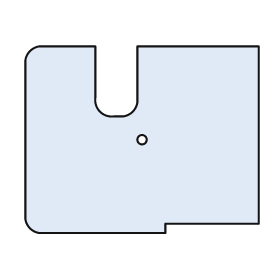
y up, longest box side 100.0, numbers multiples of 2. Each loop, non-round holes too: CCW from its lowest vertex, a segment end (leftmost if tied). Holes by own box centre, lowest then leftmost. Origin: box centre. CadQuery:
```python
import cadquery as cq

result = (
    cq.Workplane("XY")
    .moveTo(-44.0, -40.0)
    .lineTo(10.0, -40.0)
    .lineTo(10.0, -36.0)
    .lineTo(50.0, -36.0)
    .lineTo(50.0, 40.0)
    .lineTo(-2.0, 40.0)
    .lineTo(-2.0, 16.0)
    .threePointArc((-4.0, 12.0), (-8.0, 10.0))
    .lineTo(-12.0, 10.0)
    .threePointArc((-18.0, 12.0), (-20.0, 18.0))
    .lineTo(-20.0, 40.0)
    .lineTo(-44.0, 40.0)
    .threePointArc((-48.0, 38.0), (-50.0, 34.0))
    .lineTo(-50.0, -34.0)
    .threePointArc((-48.0, -38.0), (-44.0, -40.0))
    .close()
    .moveTo(0.0, 0.0)
    .circle(2.0)
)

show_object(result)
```